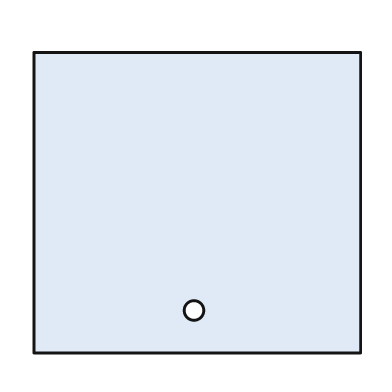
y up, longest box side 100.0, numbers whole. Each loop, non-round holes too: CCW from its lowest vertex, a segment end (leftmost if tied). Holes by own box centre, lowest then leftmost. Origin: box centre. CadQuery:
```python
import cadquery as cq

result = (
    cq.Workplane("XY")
    .moveTo(-50.0, -46.0)
    .lineTo(50.0, -46.0)
    .lineTo(50.0, 46.0)
    .lineTo(-50.0, 46.0)
    .close()
    .moveTo(-1.0, -33.0)
    .circle(3.0)
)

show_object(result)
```